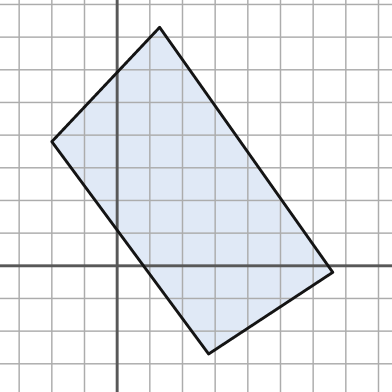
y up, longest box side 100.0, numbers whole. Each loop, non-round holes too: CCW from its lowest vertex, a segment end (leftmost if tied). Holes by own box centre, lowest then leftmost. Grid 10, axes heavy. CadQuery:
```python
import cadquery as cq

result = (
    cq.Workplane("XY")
    .moveTo(28.0, -27.0)
    .lineTo(66.0, -2.0)
    .lineTo(13.0, 73.0)
    .lineTo(-20.0, 38.0)
    .close()
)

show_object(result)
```